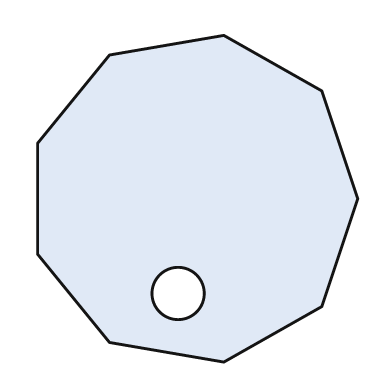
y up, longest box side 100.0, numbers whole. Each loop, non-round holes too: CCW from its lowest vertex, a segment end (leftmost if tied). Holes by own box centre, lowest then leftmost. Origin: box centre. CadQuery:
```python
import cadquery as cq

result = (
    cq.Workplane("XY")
    .moveTo(8.0, -50.0)
    .lineTo(38.0, -33.0)
    .lineTo(49.0, 0.0)
    .lineTo(38.0, 33.0)
    .lineTo(8.0, 50.0)
    .lineTo(-27.0, 44.0)
    .lineTo(-49.0, 17.0)
    .lineTo(-49.0, -17.0)
    .lineTo(-27.0, -44.0)
    .close()
    .moveTo(-6.0, -29.0)
    .circle(8.0)
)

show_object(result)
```